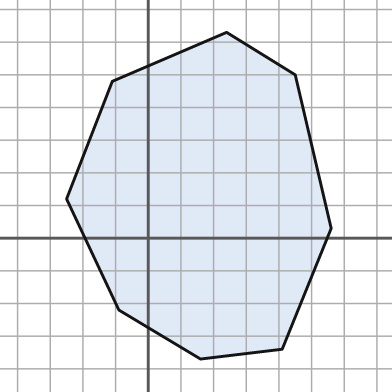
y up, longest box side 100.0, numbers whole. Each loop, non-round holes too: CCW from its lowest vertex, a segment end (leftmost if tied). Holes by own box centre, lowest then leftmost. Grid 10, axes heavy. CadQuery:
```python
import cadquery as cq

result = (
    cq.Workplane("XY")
    .moveTo(16.0, -37.0)
    .lineTo(41.0, -34.0)
    .lineTo(56.0, 3.0)
    .lineTo(45.0, 50.0)
    .lineTo(24.0, 63.0)
    .lineTo(-11.0, 48.0)
    .lineTo(-25.0, 12.0)
    .lineTo(-9.0, -22.0)
    .close()
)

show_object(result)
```